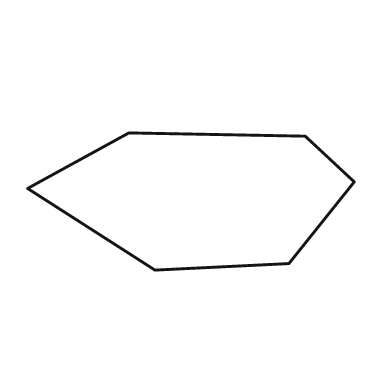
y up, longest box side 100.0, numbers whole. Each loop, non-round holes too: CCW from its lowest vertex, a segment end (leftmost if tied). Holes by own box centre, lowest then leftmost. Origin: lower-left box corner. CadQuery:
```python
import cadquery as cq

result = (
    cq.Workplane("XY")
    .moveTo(39.0, 0.0)
    .lineTo(80.0, 2.0)
    .lineTo(100.0, 27.0)
    .lineTo(85.0, 41.0)
    .lineTo(31.0, 42.0)
    .lineTo(0.0, 25.0)
    .close()
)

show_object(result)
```